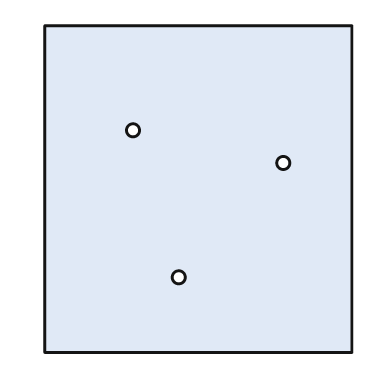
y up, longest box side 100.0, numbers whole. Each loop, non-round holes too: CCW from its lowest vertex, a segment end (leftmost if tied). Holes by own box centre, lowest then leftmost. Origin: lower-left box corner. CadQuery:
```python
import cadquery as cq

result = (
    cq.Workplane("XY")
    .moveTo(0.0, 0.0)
    .lineTo(94.0, 0.0)
    .lineTo(94.0, 100.0)
    .lineTo(0.0, 100.0)
    .close()
    .moveTo(41.0, 23.0)
    .circle(2.0)
    .moveTo(73.0, 58.0)
    .circle(2.0)
    .moveTo(27.0, 68.0)
    .circle(2.0)
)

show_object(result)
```